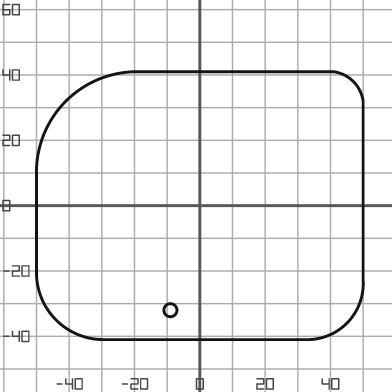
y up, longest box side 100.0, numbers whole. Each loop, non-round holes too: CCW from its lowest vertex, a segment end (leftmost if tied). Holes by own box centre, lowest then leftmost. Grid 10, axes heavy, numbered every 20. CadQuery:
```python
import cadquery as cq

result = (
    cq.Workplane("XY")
    .moveTo(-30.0, -41.0)
    .lineTo(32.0, -41.0)
    .threePointArc((45.0, -36.0), (50.0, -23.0))
    .lineTo(50.0, 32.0)
    .threePointArc((47.0, 38.0), (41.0, 41.0))
    .lineTo(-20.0, 41.0)
    .threePointArc((-41.0, 32.0), (-50.0, 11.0))
    .lineTo(-50.0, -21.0)
    .threePointArc((-44.0, -35.0), (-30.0, -41.0))
    .close()
    .moveTo(-9.0, -32.0)
    .circle(2.0)
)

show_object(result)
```